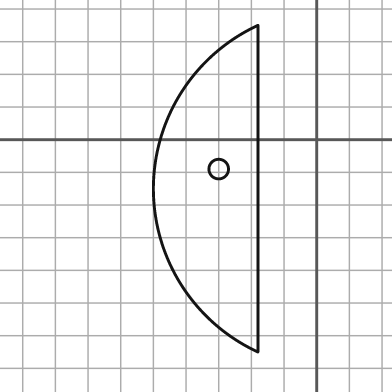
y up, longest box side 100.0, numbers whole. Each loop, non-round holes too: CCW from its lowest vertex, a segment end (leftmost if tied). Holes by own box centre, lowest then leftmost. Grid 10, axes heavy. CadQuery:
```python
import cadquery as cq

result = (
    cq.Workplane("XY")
    .moveTo(-18.0, -65.0)
    .lineTo(-18.0, 35.0)
    .threePointArc((-50.0, -15.0), (-18.0, -65.0))
    .close()
    .moveTo(-30.0, -9.0)
    .circle(3.0)
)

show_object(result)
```